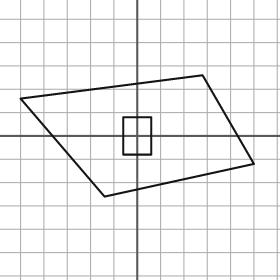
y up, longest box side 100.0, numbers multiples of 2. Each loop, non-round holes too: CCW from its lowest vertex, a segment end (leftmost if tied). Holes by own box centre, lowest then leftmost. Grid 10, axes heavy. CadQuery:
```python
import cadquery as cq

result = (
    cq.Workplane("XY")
    .moveTo(-14.0, -26.0)
    .lineTo(50.0, -12.0)
    .lineTo(28.0, 26.0)
    .lineTo(-50.0, 16.0)
    .close()
    .moveTo(-6.0, -8.0)
    .lineTo(6.0, -8.0)
    .lineTo(6.0, 8.0)
    .lineTo(-6.0, 8.0)
    .close()
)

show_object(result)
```